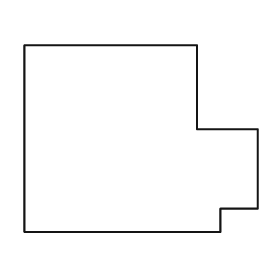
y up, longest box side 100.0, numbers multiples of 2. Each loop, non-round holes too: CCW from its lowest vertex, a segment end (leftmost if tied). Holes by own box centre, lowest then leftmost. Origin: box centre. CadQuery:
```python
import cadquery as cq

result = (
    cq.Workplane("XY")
    .moveTo(-50.0, -40.0)
    .lineTo(34.0, -40.0)
    .lineTo(34.0, -30.0)
    .lineTo(50.0, -30.0)
    .lineTo(50.0, 4.0)
    .lineTo(24.0, 4.0)
    .lineTo(24.0, 40.0)
    .lineTo(-50.0, 40.0)
    .close()
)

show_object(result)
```